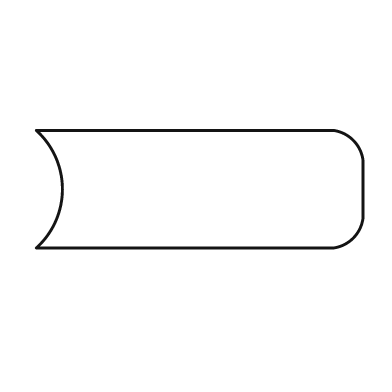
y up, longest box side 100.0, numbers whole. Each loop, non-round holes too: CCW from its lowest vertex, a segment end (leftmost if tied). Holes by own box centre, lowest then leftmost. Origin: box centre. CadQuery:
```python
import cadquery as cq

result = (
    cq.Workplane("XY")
    .moveTo(-50.0, -18.0)
    .lineTo(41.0, -18.0)
    .threePointArc((47.0, -15.0), (50.0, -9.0))
    .lineTo(50.0, 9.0)
    .threePointArc((47.0, 15.0), (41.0, 18.0))
    .lineTo(-50.0, 18.0)
    .threePointArc((-42.0, 0.0), (-50.0, -18.0))
    .close()
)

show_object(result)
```